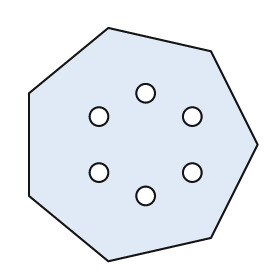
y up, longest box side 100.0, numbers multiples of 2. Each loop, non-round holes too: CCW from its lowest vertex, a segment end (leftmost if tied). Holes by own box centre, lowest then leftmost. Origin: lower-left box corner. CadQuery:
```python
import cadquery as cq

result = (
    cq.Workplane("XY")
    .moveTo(34.0, 0.0)
    .lineTo(78.0, 10.0)
    .lineTo(98.0, 50.0)
    .lineTo(78.0, 90.0)
    .lineTo(34.0, 100.0)
    .lineTo(0.0, 72.0)
    .lineTo(0.0, 28.0)
    .close()
    .moveTo(50.0, 28.0)
    .circle(4.0)
    .moveTo(30.0, 38.0)
    .circle(4.0)
    .moveTo(70.0, 38.0)
    .circle(4.0)
    .moveTo(30.0, 62.0)
    .circle(4.0)
    .moveTo(70.0, 62.0)
    .circle(4.0)
    .moveTo(50.0, 72.0)
    .circle(4.0)
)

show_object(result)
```